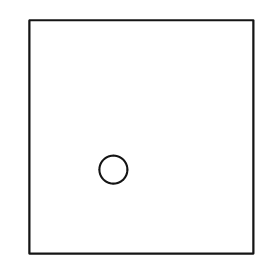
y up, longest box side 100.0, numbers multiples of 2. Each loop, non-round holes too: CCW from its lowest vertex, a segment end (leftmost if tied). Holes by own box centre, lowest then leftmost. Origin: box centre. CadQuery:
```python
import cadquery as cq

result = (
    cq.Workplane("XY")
    .moveTo(-48.0, -50.0)
    .lineTo(48.0, -50.0)
    .lineTo(48.0, 50.0)
    .lineTo(-48.0, 50.0)
    .close()
    .moveTo(-12.0, -14.0)
    .circle(6.0)
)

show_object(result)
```